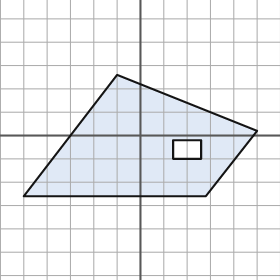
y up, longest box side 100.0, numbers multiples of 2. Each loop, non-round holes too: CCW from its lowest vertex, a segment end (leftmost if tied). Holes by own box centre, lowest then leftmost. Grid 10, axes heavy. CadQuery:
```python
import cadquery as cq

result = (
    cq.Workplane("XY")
    .moveTo(-50.0, -26.0)
    .lineTo(28.0, -26.0)
    .lineTo(50.0, 2.0)
    .lineTo(-10.0, 26.0)
    .close()
    .moveTo(14.0, -10.0)
    .lineTo(26.0, -10.0)
    .lineTo(26.0, -2.0)
    .lineTo(14.0, -2.0)
    .close()
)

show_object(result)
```